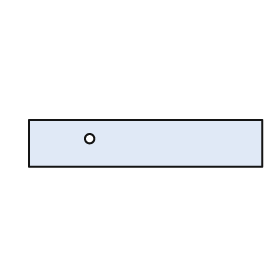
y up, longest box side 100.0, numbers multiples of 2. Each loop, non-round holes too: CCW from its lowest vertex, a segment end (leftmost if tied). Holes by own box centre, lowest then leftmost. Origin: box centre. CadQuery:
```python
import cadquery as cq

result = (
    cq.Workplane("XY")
    .moveTo(-50.0, -10.0)
    .lineTo(50.0, -10.0)
    .lineTo(50.0, 10.0)
    .lineTo(-50.0, 10.0)
    .close()
    .moveTo(-24.0, 2.0)
    .circle(2.0)
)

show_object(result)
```